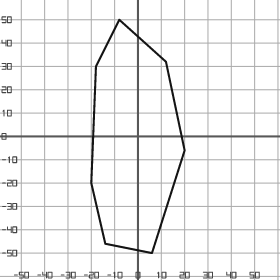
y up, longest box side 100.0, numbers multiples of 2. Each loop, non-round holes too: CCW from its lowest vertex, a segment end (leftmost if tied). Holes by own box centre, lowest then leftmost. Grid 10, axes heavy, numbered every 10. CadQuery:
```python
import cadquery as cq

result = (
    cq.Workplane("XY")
    .moveTo(6.0, -50.0)
    .lineTo(20.0, -6.0)
    .lineTo(12.0, 32.0)
    .lineTo(-8.0, 50.0)
    .lineTo(-18.0, 30.0)
    .lineTo(-20.0, -20.0)
    .lineTo(-14.0, -46.0)
    .close()
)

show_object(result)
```